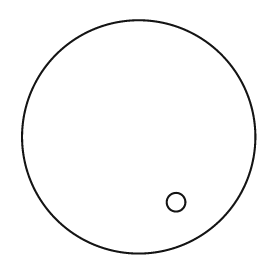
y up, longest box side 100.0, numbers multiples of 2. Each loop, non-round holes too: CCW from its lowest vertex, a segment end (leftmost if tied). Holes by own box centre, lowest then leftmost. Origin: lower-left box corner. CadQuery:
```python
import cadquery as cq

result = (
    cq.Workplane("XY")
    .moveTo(50.0, 50.0)
    .circle(50.0)
    .moveTo(66.0, 22.0)
    .circle(4.0)
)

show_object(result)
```